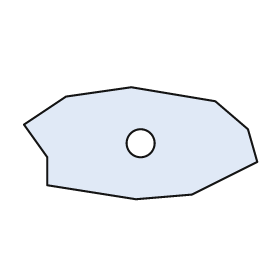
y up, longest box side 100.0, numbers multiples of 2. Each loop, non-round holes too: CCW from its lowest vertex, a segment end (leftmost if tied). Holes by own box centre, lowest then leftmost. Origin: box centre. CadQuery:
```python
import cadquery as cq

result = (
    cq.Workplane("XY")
    .moveTo(-2.0, -24.0)
    .lineTo(22.0, -22.0)
    .lineTo(50.0, -8.0)
    .lineTo(46.0, 6.0)
    .lineTo(32.0, 18.0)
    .lineTo(-4.0, 24.0)
    .lineTo(-32.0, 20.0)
    .lineTo(-50.0, 8.0)
    .lineTo(-40.0, -6.0)
    .lineTo(-40.0, -18.0)
    .close()
    .moveTo(0.0, 0.0)
    .circle(6.0)
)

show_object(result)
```